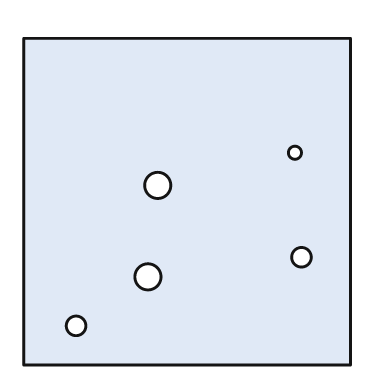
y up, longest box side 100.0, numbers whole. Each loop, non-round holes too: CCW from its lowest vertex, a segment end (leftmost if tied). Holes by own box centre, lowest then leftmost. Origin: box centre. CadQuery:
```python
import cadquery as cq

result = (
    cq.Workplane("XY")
    .moveTo(-50.0, -50.0)
    .lineTo(50.0, -50.0)
    .lineTo(50.0, 50.0)
    .lineTo(-50.0, 50.0)
    .close()
    .moveTo(-34.0, -38.0)
    .circle(3.0)
    .moveTo(-12.0, -23.0)
    .circle(4.0)
    .moveTo(35.0, -17.0)
    .circle(3.0)
    .moveTo(-9.0, 5.0)
    .circle(4.0)
    .moveTo(33.0, 15.0)
    .circle(2.0)
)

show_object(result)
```